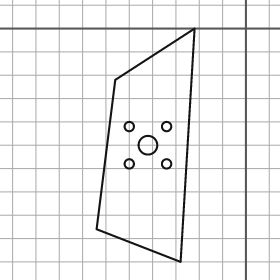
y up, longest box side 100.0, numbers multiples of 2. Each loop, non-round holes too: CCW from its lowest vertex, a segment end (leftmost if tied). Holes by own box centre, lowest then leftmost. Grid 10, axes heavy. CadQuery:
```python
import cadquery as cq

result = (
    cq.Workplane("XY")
    .moveTo(-28.0, -100.0)
    .lineTo(-22.0, 0.0)
    .lineTo(-56.0, -22.0)
    .lineTo(-64.0, -86.0)
    .close()
    .moveTo(-50.0, -58.0)
    .circle(2.0)
    .moveTo(-34.0, -58.0)
    .circle(2.0)
    .moveTo(-42.0, -50.0)
    .circle(4.0)
    .moveTo(-50.0, -42.0)
    .circle(2.0)
    .moveTo(-34.0, -42.0)
    .circle(2.0)
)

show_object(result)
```